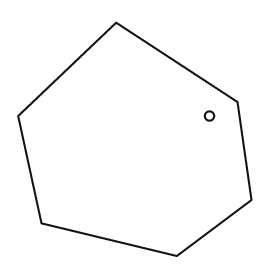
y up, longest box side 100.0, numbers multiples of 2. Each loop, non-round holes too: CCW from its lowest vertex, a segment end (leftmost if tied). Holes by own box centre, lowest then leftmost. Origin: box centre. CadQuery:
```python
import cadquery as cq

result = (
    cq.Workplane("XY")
    .moveTo(18.0, -50.0)
    .lineTo(50.0, -26.0)
    .lineTo(44.0, 16.0)
    .lineTo(-8.0, 50.0)
    .lineTo(-50.0, 10.0)
    .lineTo(-40.0, -36.0)
    .close()
    .moveTo(32.0, 10.0)
    .circle(2.0)
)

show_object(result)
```